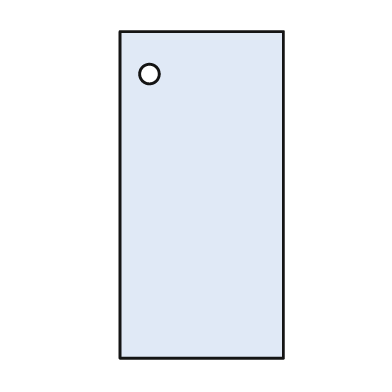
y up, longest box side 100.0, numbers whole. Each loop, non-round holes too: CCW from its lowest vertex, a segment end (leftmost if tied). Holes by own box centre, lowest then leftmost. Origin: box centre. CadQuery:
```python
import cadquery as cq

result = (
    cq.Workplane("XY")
    .moveTo(-25.0, -50.0)
    .lineTo(25.0, -50.0)
    .lineTo(25.0, 50.0)
    .lineTo(-25.0, 50.0)
    .close()
    .moveTo(-16.0, 37.0)
    .circle(3.0)
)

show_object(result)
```